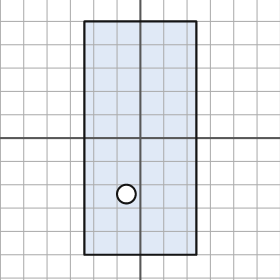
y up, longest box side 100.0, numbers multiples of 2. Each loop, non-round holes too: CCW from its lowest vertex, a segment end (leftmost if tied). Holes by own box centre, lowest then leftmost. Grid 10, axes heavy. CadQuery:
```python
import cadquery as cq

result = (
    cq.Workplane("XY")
    .moveTo(-24.0, -50.0)
    .lineTo(24.0, -50.0)
    .lineTo(24.0, 50.0)
    .lineTo(-24.0, 50.0)
    .close()
    .moveTo(-6.0, -24.0)
    .circle(4.0)
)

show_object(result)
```